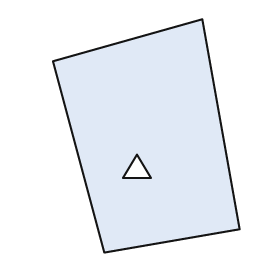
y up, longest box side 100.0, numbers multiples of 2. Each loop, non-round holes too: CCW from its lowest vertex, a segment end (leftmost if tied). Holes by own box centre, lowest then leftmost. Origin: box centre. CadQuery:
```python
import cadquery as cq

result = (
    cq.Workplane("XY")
    .moveTo(-18.0, -50.0)
    .lineTo(40.0, -40.0)
    .lineTo(24.0, 50.0)
    .lineTo(-40.0, 32.0)
    .close()
    .moveTo(-10.0, -18.0)
    .lineTo(2.0, -18.0)
    .lineTo(-4.0, -8.0)
    .close()
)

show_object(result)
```